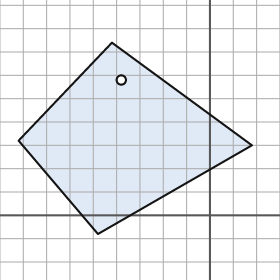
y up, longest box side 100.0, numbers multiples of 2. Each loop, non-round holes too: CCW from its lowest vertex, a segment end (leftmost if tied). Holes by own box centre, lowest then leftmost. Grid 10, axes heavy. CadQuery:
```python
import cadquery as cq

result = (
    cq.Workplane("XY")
    .moveTo(-48.0, -8.0)
    .lineTo(18.0, 30.0)
    .lineTo(-42.0, 74.0)
    .lineTo(-82.0, 32.0)
    .close()
    .moveTo(-38.0, 58.0)
    .circle(2.0)
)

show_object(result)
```